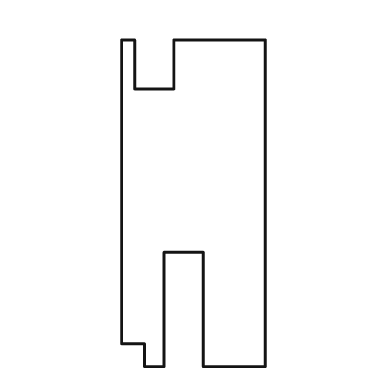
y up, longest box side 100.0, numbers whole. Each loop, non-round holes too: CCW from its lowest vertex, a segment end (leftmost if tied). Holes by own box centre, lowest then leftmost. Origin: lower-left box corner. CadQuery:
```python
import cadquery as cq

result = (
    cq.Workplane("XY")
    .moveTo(7.0, 0.0)
    .lineTo(13.0, 0.0)
    .lineTo(13.0, 35.0)
    .lineTo(25.0, 35.0)
    .lineTo(25.0, 0.0)
    .lineTo(44.0, 0.0)
    .lineTo(44.0, 100.0)
    .lineTo(16.0, 100.0)
    .lineTo(16.0, 85.0)
    .lineTo(4.0, 85.0)
    .lineTo(4.0, 100.0)
    .lineTo(0.0, 100.0)
    .lineTo(0.0, 7.0)
    .lineTo(7.0, 7.0)
    .close()
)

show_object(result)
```